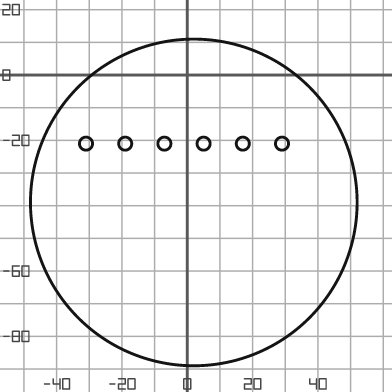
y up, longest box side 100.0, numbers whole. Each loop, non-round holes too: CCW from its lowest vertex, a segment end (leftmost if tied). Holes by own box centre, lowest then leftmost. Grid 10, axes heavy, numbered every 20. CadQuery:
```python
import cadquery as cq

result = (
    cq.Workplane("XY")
    .moveTo(2.0, -39.0)
    .circle(50.0)
    .moveTo(-31.0, -21.0)
    .circle(2.0)
    .moveTo(-19.0, -21.0)
    .circle(2.0)
    .moveTo(-7.0, -21.0)
    .circle(2.0)
    .moveTo(5.0, -21.0)
    .circle(2.0)
    .moveTo(17.0, -21.0)
    .circle(2.0)
    .moveTo(29.0, -21.0)
    .circle(2.0)
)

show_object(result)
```